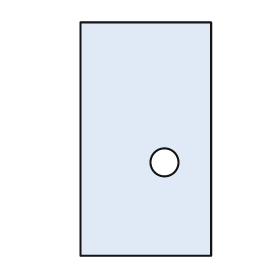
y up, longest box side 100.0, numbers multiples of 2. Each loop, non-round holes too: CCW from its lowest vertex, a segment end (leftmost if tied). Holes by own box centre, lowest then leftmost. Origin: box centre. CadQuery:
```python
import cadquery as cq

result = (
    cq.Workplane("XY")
    .moveTo(-28.0, -50.0)
    .lineTo(28.0, -50.0)
    .lineTo(28.0, 50.0)
    .lineTo(-28.0, 50.0)
    .close()
    .moveTo(8.0, -10.0)
    .circle(6.0)
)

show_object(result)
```